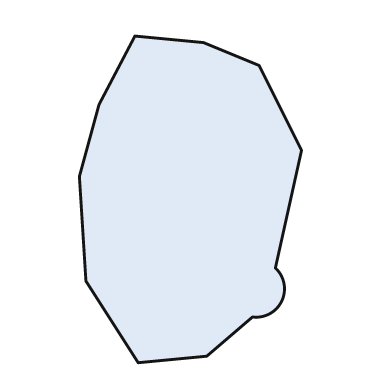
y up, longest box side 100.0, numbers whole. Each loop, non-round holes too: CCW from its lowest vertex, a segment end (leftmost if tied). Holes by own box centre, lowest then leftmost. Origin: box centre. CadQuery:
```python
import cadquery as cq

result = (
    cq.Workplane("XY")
    .moveTo(-16.0, -50.0)
    .lineTo(5.0, -48.0)
    .lineTo(19.0, -36.0)
    .threePointArc((28.0, -31.0), (26.0, -21.0))
    .lineTo(34.0, 15.0)
    .lineTo(21.0, 41.0)
    .lineTo(4.0, 48.0)
    .lineTo(-17.0, 50.0)
    .lineTo(-28.0, 29.0)
    .lineTo(-34.0, 7.0)
    .lineTo(-32.0, -25.0)
    .close()
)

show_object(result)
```